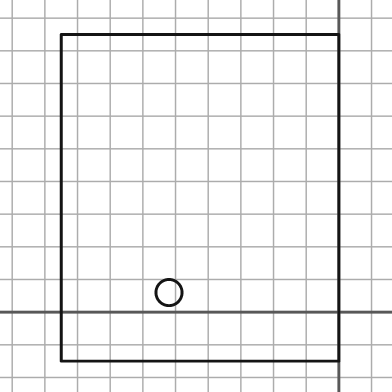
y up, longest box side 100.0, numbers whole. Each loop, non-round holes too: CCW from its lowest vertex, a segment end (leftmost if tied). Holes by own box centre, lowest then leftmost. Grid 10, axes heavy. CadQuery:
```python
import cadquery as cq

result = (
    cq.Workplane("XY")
    .moveTo(-85.0, -15.0)
    .lineTo(0.0, -15.0)
    .lineTo(0.0, 85.0)
    .lineTo(-85.0, 85.0)
    .close()
    .moveTo(-52.0, 6.0)
    .circle(4.0)
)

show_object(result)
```